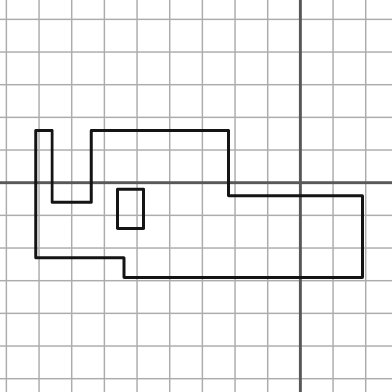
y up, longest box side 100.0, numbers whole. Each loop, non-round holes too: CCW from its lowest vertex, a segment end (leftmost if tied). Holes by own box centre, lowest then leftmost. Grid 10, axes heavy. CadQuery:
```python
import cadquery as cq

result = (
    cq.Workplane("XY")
    .moveTo(-54.0, -29.0)
    .lineTo(19.0, -29.0)
    .lineTo(19.0, -4.0)
    .lineTo(-22.0, -4.0)
    .lineTo(-22.0, 16.0)
    .lineTo(-64.0, 16.0)
    .lineTo(-64.0, -6.0)
    .lineTo(-76.0, -6.0)
    .lineTo(-76.0, 16.0)
    .lineTo(-81.0, 16.0)
    .lineTo(-81.0, -23.0)
    .lineTo(-54.0, -23.0)
    .close()
    .moveTo(-56.0, -14.0)
    .lineTo(-48.0, -14.0)
    .lineTo(-48.0, -2.0)
    .lineTo(-56.0, -2.0)
    .close()
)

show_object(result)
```